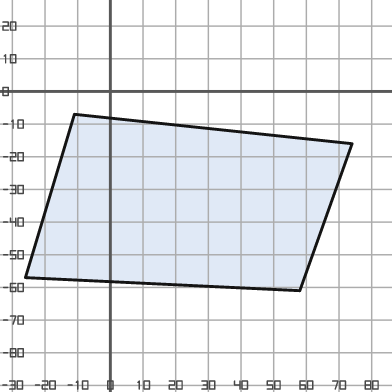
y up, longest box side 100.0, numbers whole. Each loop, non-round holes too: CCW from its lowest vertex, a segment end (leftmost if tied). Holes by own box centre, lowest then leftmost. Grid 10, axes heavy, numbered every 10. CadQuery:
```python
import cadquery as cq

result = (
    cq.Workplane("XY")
    .moveTo(58.0, -61.0)
    .lineTo(74.0, -16.0)
    .lineTo(-11.0, -7.0)
    .lineTo(-26.0, -57.0)
    .close()
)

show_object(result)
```